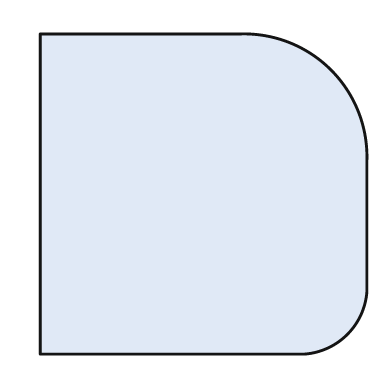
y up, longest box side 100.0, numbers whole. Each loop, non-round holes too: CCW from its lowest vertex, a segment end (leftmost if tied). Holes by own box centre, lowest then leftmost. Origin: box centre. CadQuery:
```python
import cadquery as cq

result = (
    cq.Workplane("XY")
    .moveTo(-50.0, -49.0)
    .lineTo(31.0, -49.0)
    .threePointArc((44.0, -43.0), (50.0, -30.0))
    .lineTo(50.0, 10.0)
    .threePointArc((39.0, 38.0), (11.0, 49.0))
    .lineTo(-50.0, 49.0)
    .close()
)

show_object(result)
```